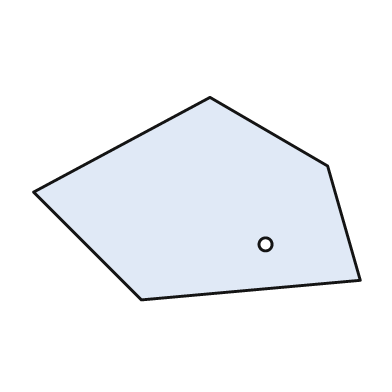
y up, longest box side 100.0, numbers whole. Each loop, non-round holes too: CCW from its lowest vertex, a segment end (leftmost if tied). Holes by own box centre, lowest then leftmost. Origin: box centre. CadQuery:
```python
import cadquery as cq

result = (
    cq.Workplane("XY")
    .moveTo(-17.0, -31.0)
    .lineTo(50.0, -25.0)
    .lineTo(40.0, 10.0)
    .lineTo(4.0, 31.0)
    .lineTo(-50.0, 2.0)
    .close()
    .moveTo(21.0, -14.0)
    .circle(2.0)
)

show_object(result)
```